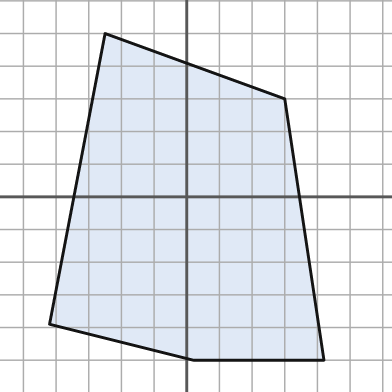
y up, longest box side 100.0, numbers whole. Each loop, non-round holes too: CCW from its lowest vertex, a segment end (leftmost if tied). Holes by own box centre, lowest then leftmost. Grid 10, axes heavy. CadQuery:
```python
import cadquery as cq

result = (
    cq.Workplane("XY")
    .moveTo(2.0, -50.0)
    .lineTo(42.0, -50.0)
    .lineTo(30.0, 30.0)
    .lineTo(-25.0, 50.0)
    .lineTo(-42.0, -39.0)
    .close()
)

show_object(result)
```